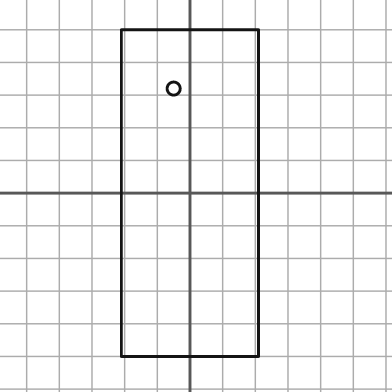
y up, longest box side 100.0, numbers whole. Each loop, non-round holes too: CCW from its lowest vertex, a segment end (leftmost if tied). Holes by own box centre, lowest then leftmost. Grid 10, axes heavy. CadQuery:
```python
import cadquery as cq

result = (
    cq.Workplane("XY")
    .moveTo(-21.0, -50.0)
    .lineTo(21.0, -50.0)
    .lineTo(21.0, 50.0)
    .lineTo(-21.0, 50.0)
    .close()
    .moveTo(-5.0, 32.0)
    .circle(2.0)
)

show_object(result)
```